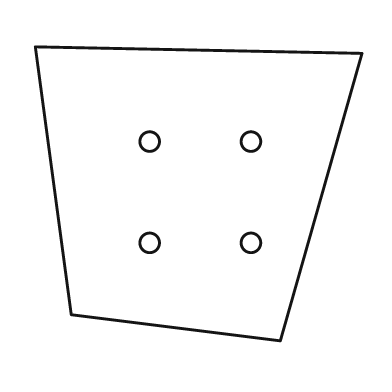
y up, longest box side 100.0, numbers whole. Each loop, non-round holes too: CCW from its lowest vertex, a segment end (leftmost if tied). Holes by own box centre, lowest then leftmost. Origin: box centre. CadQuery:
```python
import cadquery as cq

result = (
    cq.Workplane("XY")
    .moveTo(25.0, -45.0)
    .lineTo(50.0, 43.0)
    .lineTo(-50.0, 45.0)
    .lineTo(-39.0, -37.0)
    .close()
    .moveTo(-15.0, -15.0)
    .circle(3.0)
    .moveTo(16.0, -15.0)
    .circle(3.0)
    .moveTo(-15.0, 16.0)
    .circle(3.0)
    .moveTo(16.0, 16.0)
    .circle(3.0)
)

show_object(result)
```